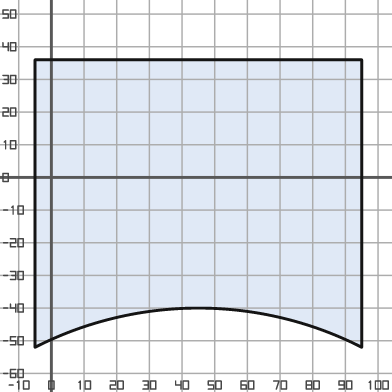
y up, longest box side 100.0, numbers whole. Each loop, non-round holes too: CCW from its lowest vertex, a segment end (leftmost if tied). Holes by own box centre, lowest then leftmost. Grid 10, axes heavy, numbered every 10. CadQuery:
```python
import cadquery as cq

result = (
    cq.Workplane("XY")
    .moveTo(-5.0, -52.0)
    .threePointArc((45.0, -40.0), (95.0, -52.0))
    .lineTo(95.0, 36.0)
    .lineTo(-5.0, 36.0)
    .close()
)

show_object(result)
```